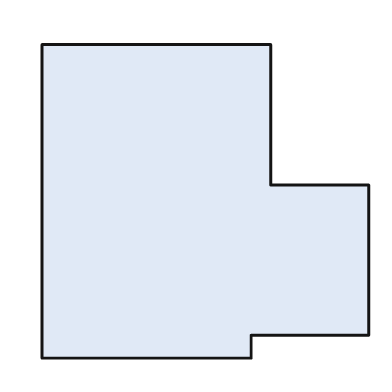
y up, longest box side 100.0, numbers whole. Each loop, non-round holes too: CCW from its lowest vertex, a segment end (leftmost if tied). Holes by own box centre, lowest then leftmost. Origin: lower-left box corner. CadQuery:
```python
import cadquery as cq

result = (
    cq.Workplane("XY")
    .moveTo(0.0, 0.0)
    .lineTo(64.0, 0.0)
    .lineTo(64.0, 7.0)
    .lineTo(100.0, 7.0)
    .lineTo(100.0, 53.0)
    .lineTo(70.0, 53.0)
    .lineTo(70.0, 96.0)
    .lineTo(0.0, 96.0)
    .close()
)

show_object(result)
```